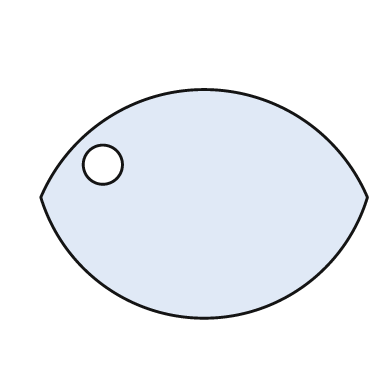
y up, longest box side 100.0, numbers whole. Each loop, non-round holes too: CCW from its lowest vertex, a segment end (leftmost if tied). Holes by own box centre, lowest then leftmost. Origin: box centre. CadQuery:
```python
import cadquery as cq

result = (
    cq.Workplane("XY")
    .moveTo(-50.0, 2.0)
    .threePointArc((0.0, -35.0), (50.0, 2.0))
    .threePointArc((0.0, 35.0), (-50.0, 2.0))
    .close()
    .moveTo(-31.0, 12.0)
    .circle(6.0)
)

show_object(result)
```